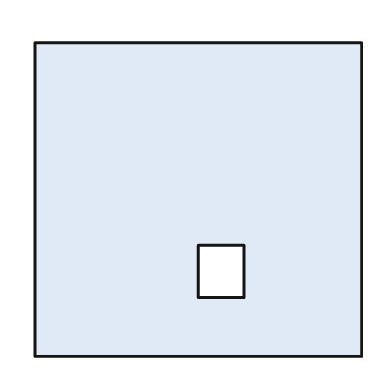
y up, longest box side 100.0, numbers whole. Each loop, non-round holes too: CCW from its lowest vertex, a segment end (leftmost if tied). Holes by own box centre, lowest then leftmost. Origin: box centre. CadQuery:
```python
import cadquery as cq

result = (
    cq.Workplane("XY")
    .moveTo(-50.0, -48.0)
    .lineTo(50.0, -48.0)
    .lineTo(50.0, 48.0)
    .lineTo(-50.0, 48.0)
    .close()
    .moveTo(0.0, -30.0)
    .lineTo(14.0, -30.0)
    .lineTo(14.0, -14.0)
    .lineTo(0.0, -14.0)
    .close()
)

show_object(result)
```